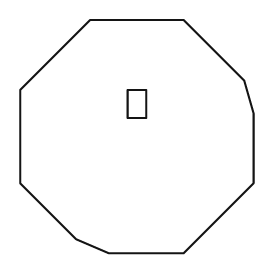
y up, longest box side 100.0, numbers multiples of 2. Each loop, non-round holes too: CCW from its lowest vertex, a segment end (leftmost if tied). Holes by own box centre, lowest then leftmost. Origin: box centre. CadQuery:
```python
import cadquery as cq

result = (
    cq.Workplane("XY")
    .moveTo(-12.0, -50.0)
    .lineTo(20.0, -50.0)
    .lineTo(50.0, -20.0)
    .lineTo(50.0, 10.0)
    .lineTo(46.0, 24.0)
    .lineTo(20.0, 50.0)
    .lineTo(-20.0, 50.0)
    .lineTo(-50.0, 20.0)
    .lineTo(-50.0, -20.0)
    .lineTo(-26.0, -44.0)
    .close()
    .moveTo(-4.0, 8.0)
    .lineTo(4.0, 8.0)
    .lineTo(4.0, 20.0)
    .lineTo(-4.0, 20.0)
    .close()
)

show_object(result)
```